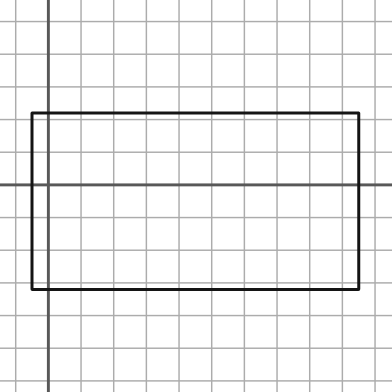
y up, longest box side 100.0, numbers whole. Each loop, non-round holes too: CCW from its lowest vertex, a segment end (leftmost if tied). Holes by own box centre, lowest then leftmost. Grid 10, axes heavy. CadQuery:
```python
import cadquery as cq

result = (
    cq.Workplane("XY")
    .moveTo(-5.0, -32.0)
    .lineTo(95.0, -32.0)
    .lineTo(95.0, 22.0)
    .lineTo(-5.0, 22.0)
    .close()
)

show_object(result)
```